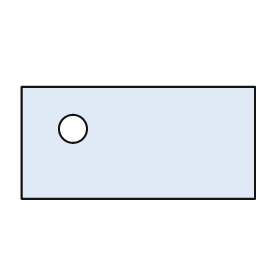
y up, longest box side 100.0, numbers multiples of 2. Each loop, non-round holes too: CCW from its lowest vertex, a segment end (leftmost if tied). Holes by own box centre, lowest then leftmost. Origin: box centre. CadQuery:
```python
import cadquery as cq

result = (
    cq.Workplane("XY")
    .moveTo(-50.0, -24.0)
    .lineTo(50.0, -24.0)
    .lineTo(50.0, 24.0)
    .lineTo(-50.0, 24.0)
    .close()
    .moveTo(-28.0, 6.0)
    .circle(6.0)
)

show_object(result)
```